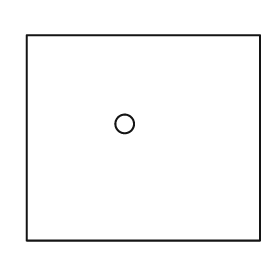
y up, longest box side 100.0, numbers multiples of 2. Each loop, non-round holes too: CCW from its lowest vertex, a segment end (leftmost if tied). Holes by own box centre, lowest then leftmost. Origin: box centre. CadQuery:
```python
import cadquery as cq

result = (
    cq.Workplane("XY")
    .moveTo(-50.0, -44.0)
    .lineTo(50.0, -44.0)
    .lineTo(50.0, 44.0)
    .lineTo(-50.0, 44.0)
    .close()
    .moveTo(-8.0, 6.0)
    .circle(4.0)
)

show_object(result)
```